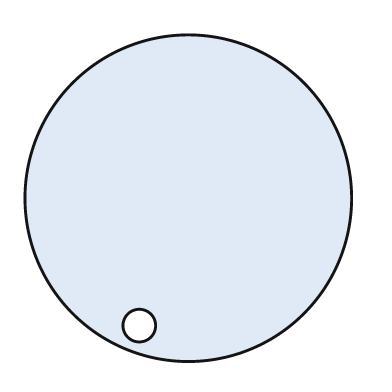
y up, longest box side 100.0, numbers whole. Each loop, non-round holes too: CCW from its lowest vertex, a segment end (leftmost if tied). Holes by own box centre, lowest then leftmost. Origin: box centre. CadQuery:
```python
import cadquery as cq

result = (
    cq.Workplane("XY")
    .moveTo(0.0, 0.0)
    .circle(50.0)
    .moveTo(-15.0, -39.0)
    .circle(5.0)
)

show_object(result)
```